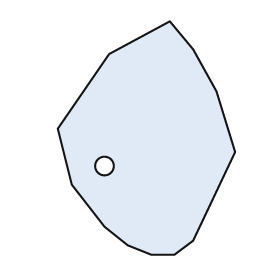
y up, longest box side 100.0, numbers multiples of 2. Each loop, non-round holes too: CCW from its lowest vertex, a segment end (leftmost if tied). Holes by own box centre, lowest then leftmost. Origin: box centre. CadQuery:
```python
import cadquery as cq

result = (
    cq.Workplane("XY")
    .moveTo(2.0, -50.0)
    .lineTo(12.0, -50.0)
    .lineTo(20.0, -44.0)
    .lineTo(38.0, -6.0)
    .lineTo(30.0, 20.0)
    .lineTo(20.0, 38.0)
    .lineTo(10.0, 50.0)
    .lineTo(-16.0, 36.0)
    .lineTo(-38.0, 4.0)
    .lineTo(-32.0, -20.0)
    .lineTo(-18.0, -38.0)
    .lineTo(-8.0, -46.0)
    .close()
    .moveTo(-18.0, -12.0)
    .circle(4.0)
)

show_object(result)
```